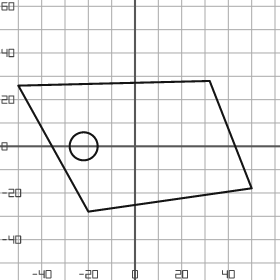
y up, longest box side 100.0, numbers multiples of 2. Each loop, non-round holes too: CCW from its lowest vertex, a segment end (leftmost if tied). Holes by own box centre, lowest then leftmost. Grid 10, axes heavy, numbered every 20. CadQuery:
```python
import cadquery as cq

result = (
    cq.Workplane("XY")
    .moveTo(-20.0, -28.0)
    .lineTo(50.0, -18.0)
    .lineTo(32.0, 28.0)
    .lineTo(-50.0, 26.0)
    .close()
    .moveTo(-22.0, 0.0)
    .circle(6.0)
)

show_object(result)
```